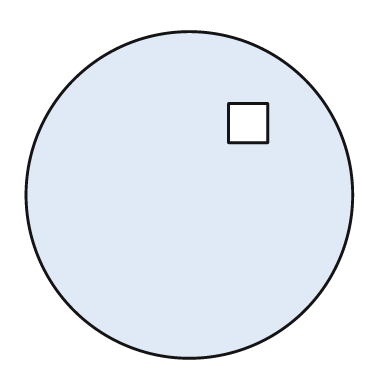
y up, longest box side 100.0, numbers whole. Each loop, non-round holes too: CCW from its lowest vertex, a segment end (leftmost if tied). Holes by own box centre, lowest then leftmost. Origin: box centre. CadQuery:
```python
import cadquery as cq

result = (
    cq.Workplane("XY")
    .moveTo(0.0, 0.0)
    .circle(50.0)
    .moveTo(12.0, 16.0)
    .lineTo(24.0, 16.0)
    .lineTo(24.0, 28.0)
    .lineTo(12.0, 28.0)
    .close()
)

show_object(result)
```